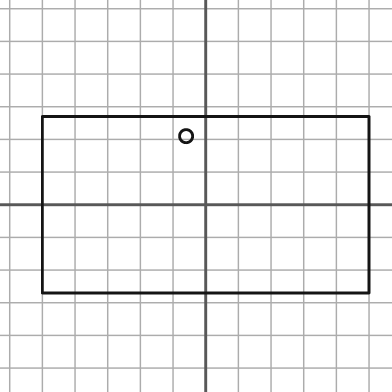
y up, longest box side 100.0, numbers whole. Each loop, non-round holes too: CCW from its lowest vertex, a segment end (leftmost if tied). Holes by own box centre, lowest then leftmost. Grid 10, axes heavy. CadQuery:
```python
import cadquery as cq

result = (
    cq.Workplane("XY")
    .moveTo(-50.0, -27.0)
    .lineTo(50.0, -27.0)
    .lineTo(50.0, 27.0)
    .lineTo(-50.0, 27.0)
    .close()
    .moveTo(-6.0, 21.0)
    .circle(2.0)
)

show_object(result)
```